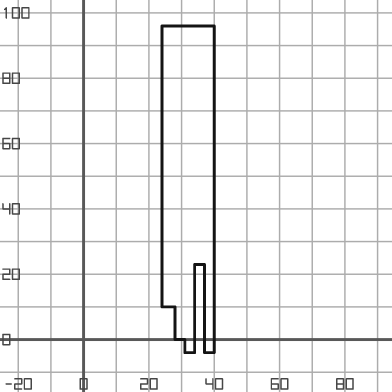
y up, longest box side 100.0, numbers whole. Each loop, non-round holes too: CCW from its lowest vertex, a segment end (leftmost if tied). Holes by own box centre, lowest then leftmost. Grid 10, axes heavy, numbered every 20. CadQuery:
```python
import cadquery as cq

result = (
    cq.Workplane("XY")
    .moveTo(31.0, -4.0)
    .lineTo(34.0, -4.0)
    .lineTo(34.0, 23.0)
    .lineTo(37.0, 23.0)
    .lineTo(37.0, -4.0)
    .lineTo(40.0, -4.0)
    .lineTo(40.0, 96.0)
    .lineTo(24.0, 96.0)
    .lineTo(24.0, 10.0)
    .lineTo(28.0, 10.0)
    .lineTo(28.0, 0.0)
    .lineTo(31.0, 0.0)
    .close()
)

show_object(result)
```